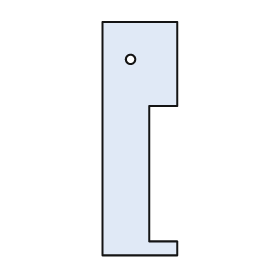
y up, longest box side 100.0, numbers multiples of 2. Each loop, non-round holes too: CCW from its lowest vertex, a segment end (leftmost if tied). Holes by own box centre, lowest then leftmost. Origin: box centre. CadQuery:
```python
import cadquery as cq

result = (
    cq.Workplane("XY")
    .moveTo(-16.0, -50.0)
    .lineTo(16.0, -50.0)
    .lineTo(16.0, -44.0)
    .lineTo(4.0, -44.0)
    .lineTo(4.0, 14.0)
    .lineTo(16.0, 14.0)
    .lineTo(16.0, 50.0)
    .lineTo(-16.0, 50.0)
    .close()
    .moveTo(-4.0, 34.0)
    .circle(2.0)
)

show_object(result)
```